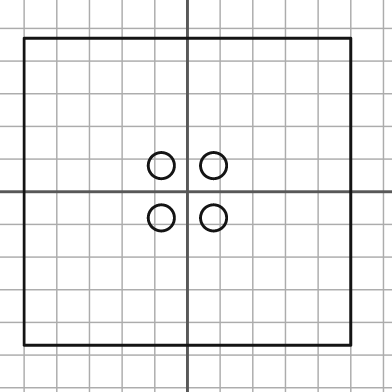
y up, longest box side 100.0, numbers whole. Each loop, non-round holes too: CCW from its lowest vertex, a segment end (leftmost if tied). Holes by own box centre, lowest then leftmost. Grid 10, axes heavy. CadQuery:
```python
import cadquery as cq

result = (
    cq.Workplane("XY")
    .moveTo(-50.0, -47.0)
    .lineTo(50.0, -47.0)
    .lineTo(50.0, 47.0)
    .lineTo(-50.0, 47.0)
    .close()
    .moveTo(-8.0, -8.0)
    .circle(4.0)
    .moveTo(8.0, -8.0)
    .circle(4.0)
    .moveTo(-8.0, 8.0)
    .circle(4.0)
    .moveTo(8.0, 8.0)
    .circle(4.0)
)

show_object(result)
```